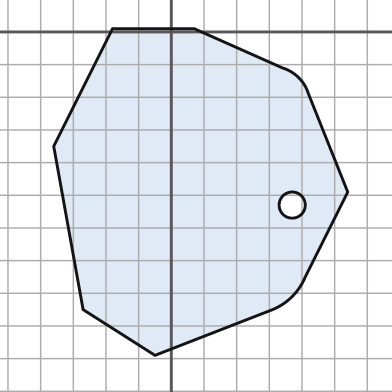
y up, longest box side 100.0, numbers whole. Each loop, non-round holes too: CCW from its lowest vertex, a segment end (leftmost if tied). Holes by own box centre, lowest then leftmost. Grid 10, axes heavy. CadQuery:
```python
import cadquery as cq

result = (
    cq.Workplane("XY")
    .moveTo(-5.0, -99.0)
    .lineTo(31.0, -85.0)
    .threePointArc((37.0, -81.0), (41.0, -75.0))
    .lineTo(54.0, -49.0)
    .lineTo(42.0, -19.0)
    .threePointArc((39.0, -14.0), (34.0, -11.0))
    .lineTo(7.0, 1.0)
    .lineTo(-18.0, 1.0)
    .lineTo(-36.0, -35.0)
    .lineTo(-27.0, -85.0)
    .close()
    .moveTo(37.0, -53.0)
    .circle(4.0)
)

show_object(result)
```